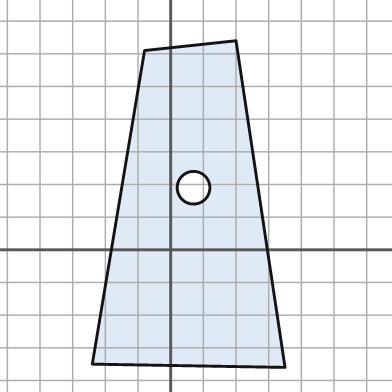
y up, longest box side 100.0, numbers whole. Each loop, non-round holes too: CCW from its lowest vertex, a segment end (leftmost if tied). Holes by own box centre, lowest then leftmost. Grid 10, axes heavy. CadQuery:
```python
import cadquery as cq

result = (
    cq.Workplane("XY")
    .moveTo(35.0, -36.0)
    .lineTo(20.0, 64.0)
    .lineTo(-8.0, 61.0)
    .lineTo(-24.0, -35.0)
    .close()
    .moveTo(7.0, 19.0)
    .circle(5.0)
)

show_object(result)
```